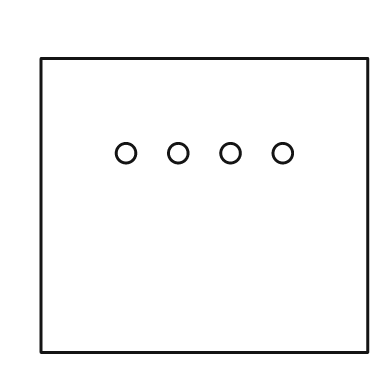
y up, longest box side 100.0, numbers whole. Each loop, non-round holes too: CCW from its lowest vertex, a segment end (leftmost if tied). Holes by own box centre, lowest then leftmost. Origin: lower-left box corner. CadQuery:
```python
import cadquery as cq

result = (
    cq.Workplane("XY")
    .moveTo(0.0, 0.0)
    .lineTo(100.0, 0.0)
    .lineTo(100.0, 90.0)
    .lineTo(0.0, 90.0)
    .close()
    .moveTo(26.0, 61.0)
    .circle(3.0)
    .moveTo(42.0, 61.0)
    .circle(3.0)
    .moveTo(58.0, 61.0)
    .circle(3.0)
    .moveTo(74.0, 61.0)
    .circle(3.0)
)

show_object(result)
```